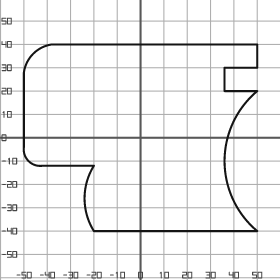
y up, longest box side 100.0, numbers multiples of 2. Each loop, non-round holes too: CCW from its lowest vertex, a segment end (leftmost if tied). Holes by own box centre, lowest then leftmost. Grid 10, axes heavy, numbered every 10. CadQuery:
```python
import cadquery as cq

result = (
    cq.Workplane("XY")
    .moveTo(-20.0, -40.0)
    .lineTo(50.0, -40.0)
    .threePointArc((36.0, -10.0), (50.0, 20.0))
    .lineTo(36.0, 20.0)
    .lineTo(36.0, 30.0)
    .lineTo(50.0, 30.0)
    .lineTo(50.0, 40.0)
    .lineTo(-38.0, 40.0)
    .threePointArc((-46.0, 36.0), (-50.0, 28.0))
    .lineTo(-50.0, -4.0)
    .threePointArc((-48.0, -10.0), (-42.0, -12.0))
    .lineTo(-20.0, -12.0)
    .threePointArc((-24.0, -26.0), (-20.0, -40.0))
    .close()
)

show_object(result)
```